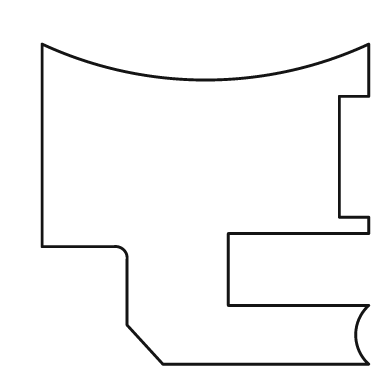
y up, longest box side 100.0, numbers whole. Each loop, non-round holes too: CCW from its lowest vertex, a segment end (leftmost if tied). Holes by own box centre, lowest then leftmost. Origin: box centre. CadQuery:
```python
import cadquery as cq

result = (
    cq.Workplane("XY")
    .moveTo(-13.0, -49.0)
    .lineTo(50.0, -49.0)
    .threePointArc((46.0, -40.0), (50.0, -31.0))
    .lineTo(7.0, -31.0)
    .lineTo(7.0, -9.0)
    .lineTo(50.0, -9.0)
    .lineTo(50.0, -4.0)
    .lineTo(41.0, -4.0)
    .lineTo(41.0, 33.0)
    .lineTo(50.0, 33.0)
    .lineTo(50.0, 49.0)
    .threePointArc((0.0, 38.0), (-50.0, 49.0))
    .lineTo(-50.0, -13.0)
    .lineTo(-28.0, -13.0)
    .threePointArc((-25.0, -14.0), (-24.0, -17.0))
    .lineTo(-24.0, -37.0)
    .close()
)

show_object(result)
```